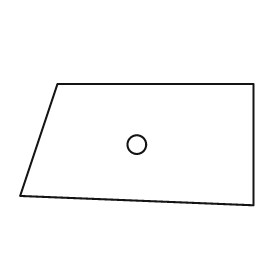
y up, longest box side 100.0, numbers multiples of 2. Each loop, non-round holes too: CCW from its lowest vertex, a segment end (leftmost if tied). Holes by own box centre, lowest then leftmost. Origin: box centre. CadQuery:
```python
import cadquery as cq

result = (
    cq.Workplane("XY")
    .moveTo(50.0, -26.0)
    .lineTo(50.0, 26.0)
    .lineTo(-34.0, 26.0)
    .lineTo(-50.0, -22.0)
    .close()
    .moveTo(0.0, 0.0)
    .circle(4.0)
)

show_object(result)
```